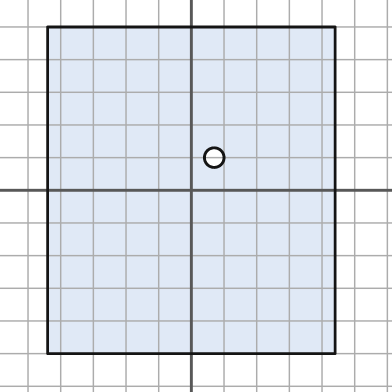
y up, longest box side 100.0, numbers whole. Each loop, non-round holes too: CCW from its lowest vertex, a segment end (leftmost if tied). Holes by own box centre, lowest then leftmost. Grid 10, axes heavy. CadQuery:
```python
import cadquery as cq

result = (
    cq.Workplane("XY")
    .moveTo(-44.0, -50.0)
    .lineTo(44.0, -50.0)
    .lineTo(44.0, 50.0)
    .lineTo(-44.0, 50.0)
    .close()
    .moveTo(7.0, 10.0)
    .circle(3.0)
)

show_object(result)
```